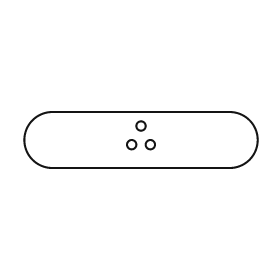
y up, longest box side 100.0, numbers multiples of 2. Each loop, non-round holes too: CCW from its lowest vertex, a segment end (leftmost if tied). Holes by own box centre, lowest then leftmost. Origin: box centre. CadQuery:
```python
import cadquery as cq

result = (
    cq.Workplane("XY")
    .moveTo(-38.0, -12.0)
    .lineTo(38.0, -12.0)
    .threePointArc((50.0, 0.0), (38.0, 12.0))
    .lineTo(-38.0, 12.0)
    .threePointArc((-50.0, 0.0), (-38.0, -12.0))
    .close()
    .moveTo(-4.0, -2.0)
    .circle(2.0)
    .moveTo(4.0, -2.0)
    .circle(2.0)
    .moveTo(0.0, 6.0)
    .circle(2.0)
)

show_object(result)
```